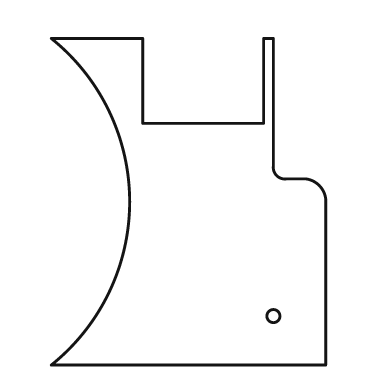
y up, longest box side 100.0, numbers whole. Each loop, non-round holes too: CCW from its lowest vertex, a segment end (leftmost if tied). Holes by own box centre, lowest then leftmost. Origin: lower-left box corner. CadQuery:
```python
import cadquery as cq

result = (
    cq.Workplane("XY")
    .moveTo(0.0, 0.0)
    .lineTo(84.0, 0.0)
    .lineTo(84.0, 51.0)
    .threePointArc((82.0, 55.0), (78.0, 57.0))
    .lineTo(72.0, 57.0)
    .threePointArc((69.0, 58.0), (68.0, 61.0))
    .lineTo(68.0, 100.0)
    .lineTo(65.0, 100.0)
    .lineTo(65.0, 74.0)
    .lineTo(28.0, 74.0)
    .lineTo(28.0, 100.0)
    .lineTo(0.0, 100.0)
    .threePointArc((24.0, 50.0), (0.0, 0.0))
    .close()
    .moveTo(68.0, 15.0)
    .circle(2.0)
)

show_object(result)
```